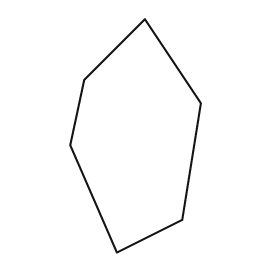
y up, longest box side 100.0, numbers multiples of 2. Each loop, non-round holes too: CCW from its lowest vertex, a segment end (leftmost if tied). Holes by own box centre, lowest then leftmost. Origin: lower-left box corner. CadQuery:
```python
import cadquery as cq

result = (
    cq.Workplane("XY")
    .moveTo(20.0, 0.0)
    .lineTo(48.0, 14.0)
    .lineTo(56.0, 64.0)
    .lineTo(32.0, 100.0)
    .lineTo(6.0, 74.0)
    .lineTo(0.0, 46.0)
    .close()
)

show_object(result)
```